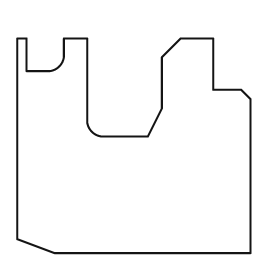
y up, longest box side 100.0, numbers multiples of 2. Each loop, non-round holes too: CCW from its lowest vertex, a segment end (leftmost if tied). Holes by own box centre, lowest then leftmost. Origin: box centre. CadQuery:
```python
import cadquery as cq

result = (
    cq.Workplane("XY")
    .moveTo(-34.0, -46.0)
    .lineTo(50.0, -46.0)
    .lineTo(50.0, 20.0)
    .lineTo(46.0, 24.0)
    .lineTo(34.0, 24.0)
    .lineTo(34.0, 46.0)
    .lineTo(20.0, 46.0)
    .lineTo(12.0, 38.0)
    .lineTo(12.0, 16.0)
    .lineTo(6.0, 4.0)
    .lineTo(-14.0, 4.0)
    .threePointArc((-18.0, 6.0), (-20.0, 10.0))
    .lineTo(-20.0, 46.0)
    .lineTo(-30.0, 46.0)
    .lineTo(-30.0, 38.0)
    .threePointArc((-32.0, 34.0), (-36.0, 32.0))
    .lineTo(-46.0, 32.0)
    .lineTo(-46.0, 46.0)
    .lineTo(-50.0, 46.0)
    .lineTo(-50.0, -40.0)
    .close()
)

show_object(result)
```